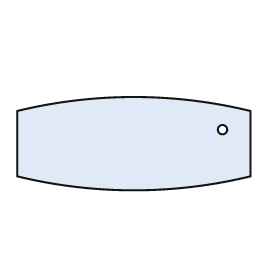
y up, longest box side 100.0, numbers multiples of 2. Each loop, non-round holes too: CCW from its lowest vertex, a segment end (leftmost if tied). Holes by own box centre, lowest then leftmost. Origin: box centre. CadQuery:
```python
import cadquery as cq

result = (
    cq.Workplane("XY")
    .moveTo(-50.0, -14.0)
    .threePointArc((0.0, -20.0), (50.0, -14.0))
    .lineTo(50.0, 14.0)
    .threePointArc((0.0, 20.0), (-50.0, 14.0))
    .close()
    .moveTo(38.0, 6.0)
    .circle(2.0)
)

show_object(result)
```